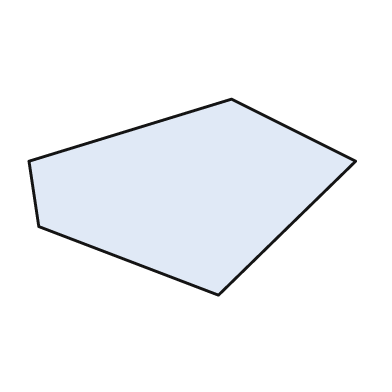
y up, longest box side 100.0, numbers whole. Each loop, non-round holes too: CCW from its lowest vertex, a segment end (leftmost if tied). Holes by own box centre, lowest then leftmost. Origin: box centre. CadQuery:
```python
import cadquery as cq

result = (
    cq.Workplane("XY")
    .moveTo(8.0, -30.0)
    .lineTo(50.0, 11.0)
    .lineTo(12.0, 30.0)
    .lineTo(-50.0, 11.0)
    .lineTo(-47.0, -9.0)
    .close()
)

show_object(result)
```